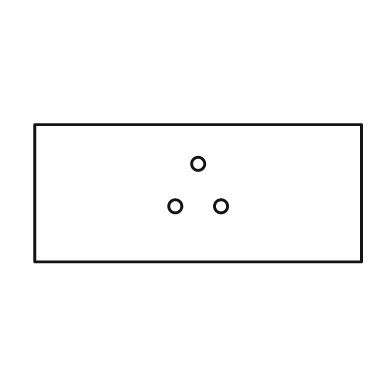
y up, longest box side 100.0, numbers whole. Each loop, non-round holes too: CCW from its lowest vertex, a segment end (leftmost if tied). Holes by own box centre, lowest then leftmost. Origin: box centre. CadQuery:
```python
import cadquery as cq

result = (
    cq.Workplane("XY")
    .moveTo(-50.0, -21.0)
    .lineTo(50.0, -21.0)
    .lineTo(50.0, 21.0)
    .lineTo(-50.0, 21.0)
    .close()
    .moveTo(-7.0, -4.0)
    .circle(2.0)
    .moveTo(7.0, -4.0)
    .circle(2.0)
    .moveTo(0.0, 9.0)
    .circle(2.0)
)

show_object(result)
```